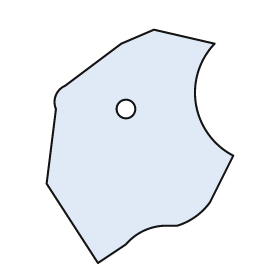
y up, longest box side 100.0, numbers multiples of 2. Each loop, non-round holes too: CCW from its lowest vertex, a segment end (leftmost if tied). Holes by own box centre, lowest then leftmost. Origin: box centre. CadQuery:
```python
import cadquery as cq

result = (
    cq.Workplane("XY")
    .moveTo(-18.0, -50.0)
    .lineTo(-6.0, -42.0)
    .threePointArc((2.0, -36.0), (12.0, -34.0))
    .lineTo(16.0, -34.0)
    .threePointArc((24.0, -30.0), (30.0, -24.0))
    .lineTo(40.0, -4.0)
    .threePointArc((24.0, 18.0), (32.0, 44.0))
    .lineTo(6.0, 50.0)
    .lineTo(-8.0, 44.0)
    .lineTo(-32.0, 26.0)
    .threePointArc((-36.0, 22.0), (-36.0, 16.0))
    .lineTo(-40.0, -16.0)
    .close()
    .moveTo(-6.0, 16.0)
    .circle(4.0)
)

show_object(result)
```